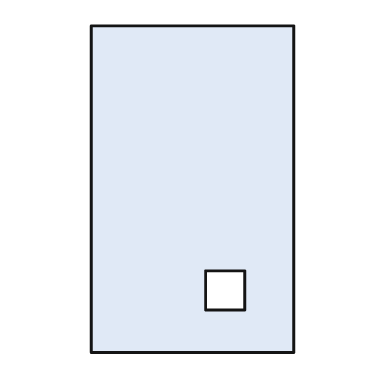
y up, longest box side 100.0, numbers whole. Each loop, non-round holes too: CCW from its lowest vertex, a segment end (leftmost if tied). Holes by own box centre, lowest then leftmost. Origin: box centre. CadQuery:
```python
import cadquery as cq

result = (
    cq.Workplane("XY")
    .moveTo(-31.0, -50.0)
    .lineTo(31.0, -50.0)
    .lineTo(31.0, 50.0)
    .lineTo(-31.0, 50.0)
    .close()
    .moveTo(4.0, -37.0)
    .lineTo(16.0, -37.0)
    .lineTo(16.0, -25.0)
    .lineTo(4.0, -25.0)
    .close()
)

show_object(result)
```